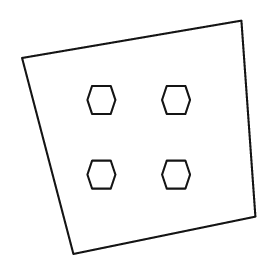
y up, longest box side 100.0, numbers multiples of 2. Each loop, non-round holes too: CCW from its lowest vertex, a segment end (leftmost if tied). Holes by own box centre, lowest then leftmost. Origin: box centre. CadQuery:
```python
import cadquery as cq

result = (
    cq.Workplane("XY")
    .moveTo(-28.0, -50.0)
    .lineTo(50.0, -34.0)
    .lineTo(44.0, 50.0)
    .lineTo(-50.0, 34.0)
    .close()
    .moveTo(-20.0, -22.0)
    .lineTo(-12.0, -22.0)
    .lineTo(-10.0, -16.0)
    .lineTo(-12.0, -10.0)
    .lineTo(-20.0, -10.0)
    .lineTo(-22.0, -16.0)
    .close()
    .moveTo(12.0, -22.0)
    .lineTo(20.0, -22.0)
    .lineTo(22.0, -16.0)
    .lineTo(20.0, -10.0)
    .lineTo(12.0, -10.0)
    .lineTo(10.0, -16.0)
    .close()
    .moveTo(-20.0, 10.0)
    .lineTo(-12.0, 10.0)
    .lineTo(-10.0, 16.0)
    .lineTo(-12.0, 22.0)
    .lineTo(-20.0, 22.0)
    .lineTo(-22.0, 16.0)
    .close()
    .moveTo(12.0, 10.0)
    .lineTo(20.0, 10.0)
    .lineTo(22.0, 16.0)
    .lineTo(20.0, 22.0)
    .lineTo(12.0, 22.0)
    .lineTo(10.0, 16.0)
    .close()
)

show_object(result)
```